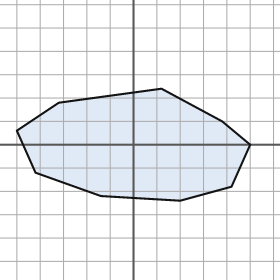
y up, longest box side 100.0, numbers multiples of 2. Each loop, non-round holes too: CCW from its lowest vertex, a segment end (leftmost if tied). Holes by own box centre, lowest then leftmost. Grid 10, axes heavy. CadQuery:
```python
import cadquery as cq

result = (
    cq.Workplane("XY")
    .moveTo(20.0, -24.0)
    .lineTo(42.0, -18.0)
    .lineTo(50.0, 0.0)
    .lineTo(38.0, 10.0)
    .lineTo(12.0, 24.0)
    .lineTo(-32.0, 18.0)
    .lineTo(-50.0, 6.0)
    .lineTo(-42.0, -12.0)
    .lineTo(-14.0, -22.0)
    .close()
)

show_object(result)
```